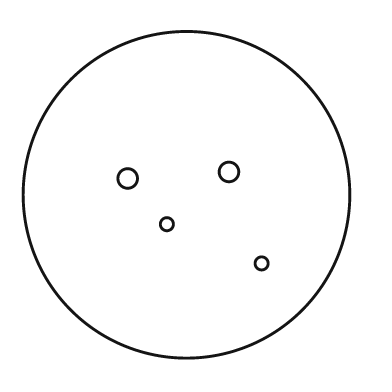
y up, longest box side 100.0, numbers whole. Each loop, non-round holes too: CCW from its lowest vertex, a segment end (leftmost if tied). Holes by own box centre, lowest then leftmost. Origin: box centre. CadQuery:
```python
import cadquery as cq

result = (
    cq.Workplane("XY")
    .moveTo(0.0, 0.0)
    .circle(50.0)
    .moveTo(23.0, -21.0)
    .circle(2.0)
    .moveTo(-6.0, -9.0)
    .circle(2.0)
    .moveTo(-18.0, 5.0)
    .circle(3.0)
    .moveTo(13.0, 7.0)
    .circle(3.0)
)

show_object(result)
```